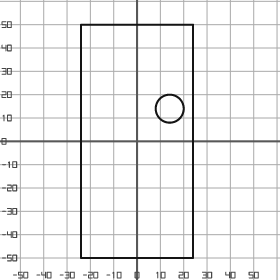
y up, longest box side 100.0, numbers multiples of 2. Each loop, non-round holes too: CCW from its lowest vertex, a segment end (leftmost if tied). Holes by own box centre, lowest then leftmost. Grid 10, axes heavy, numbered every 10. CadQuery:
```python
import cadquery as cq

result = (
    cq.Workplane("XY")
    .moveTo(-24.0, -50.0)
    .lineTo(24.0, -50.0)
    .lineTo(24.0, 50.0)
    .lineTo(-24.0, 50.0)
    .close()
    .moveTo(14.0, 14.0)
    .circle(6.0)
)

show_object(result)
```